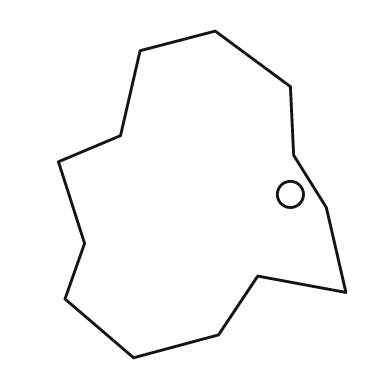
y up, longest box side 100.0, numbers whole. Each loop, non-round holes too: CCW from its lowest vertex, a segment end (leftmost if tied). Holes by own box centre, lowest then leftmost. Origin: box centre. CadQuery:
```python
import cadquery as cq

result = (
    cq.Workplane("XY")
    .moveTo(-21.0, -50.0)
    .lineTo(5.0, -43.0)
    .lineTo(17.0, -25.0)
    .lineTo(44.0, -30.0)
    .lineTo(38.0, -4.0)
    .lineTo(28.0, 12.0)
    .lineTo(27.0, 33.0)
    .lineTo(4.0, 50.0)
    .lineTo(-19.0, 44.0)
    .lineTo(-25.0, 18.0)
    .lineTo(-44.0, 10.0)
    .lineTo(-36.0, -15.0)
    .lineTo(-42.0, -32.0)
    .close()
    .moveTo(27.0, 0.0)
    .circle(4.0)
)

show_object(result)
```